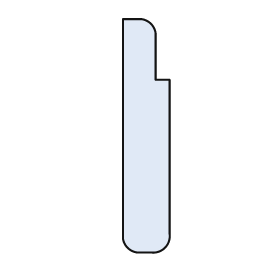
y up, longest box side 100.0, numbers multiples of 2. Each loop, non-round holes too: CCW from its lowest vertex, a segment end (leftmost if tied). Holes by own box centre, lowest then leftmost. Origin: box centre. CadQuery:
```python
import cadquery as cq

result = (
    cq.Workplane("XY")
    .moveTo(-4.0, -50.0)
    .lineTo(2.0, -50.0)
    .threePointArc((8.0, -48.0), (10.0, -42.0))
    .lineTo(10.0, 24.0)
    .lineTo(4.0, 24.0)
    .lineTo(4.0, 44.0)
    .threePointArc((2.0, 48.0), (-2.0, 50.0))
    .lineTo(-10.0, 50.0)
    .lineTo(-10.0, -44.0)
    .threePointArc((-8.0, -48.0), (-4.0, -50.0))
    .close()
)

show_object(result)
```